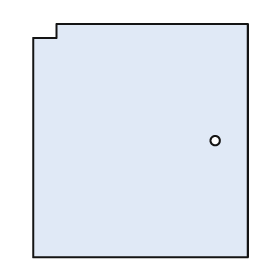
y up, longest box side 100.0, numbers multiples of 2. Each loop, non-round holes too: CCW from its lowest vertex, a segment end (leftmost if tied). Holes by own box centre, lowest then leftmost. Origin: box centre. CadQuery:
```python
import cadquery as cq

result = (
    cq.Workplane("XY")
    .moveTo(-46.0, -50.0)
    .lineTo(46.0, -50.0)
    .lineTo(46.0, 50.0)
    .lineTo(-36.0, 50.0)
    .lineTo(-36.0, 44.0)
    .lineTo(-46.0, 44.0)
    .close()
    .moveTo(32.0, 0.0)
    .circle(2.0)
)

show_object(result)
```